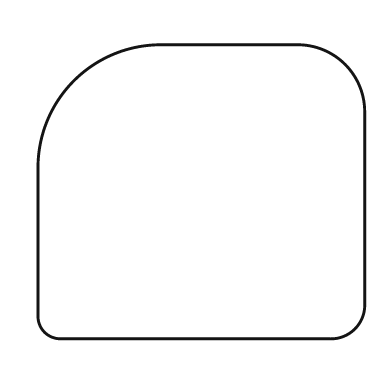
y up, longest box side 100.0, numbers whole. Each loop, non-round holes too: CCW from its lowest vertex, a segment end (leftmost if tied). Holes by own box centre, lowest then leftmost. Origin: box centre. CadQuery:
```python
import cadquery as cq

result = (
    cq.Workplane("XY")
    .moveTo(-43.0, -45.0)
    .lineTo(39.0, -45.0)
    .threePointArc((47.0, -42.0), (50.0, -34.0))
    .lineTo(50.0, 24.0)
    .threePointArc((44.0, 39.0), (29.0, 45.0))
    .lineTo(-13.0, 45.0)
    .threePointArc((-39.0, 34.0), (-50.0, 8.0))
    .lineTo(-50.0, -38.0)
    .threePointArc((-48.0, -43.0), (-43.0, -45.0))
    .close()
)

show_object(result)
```